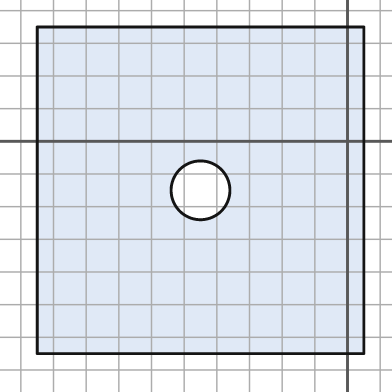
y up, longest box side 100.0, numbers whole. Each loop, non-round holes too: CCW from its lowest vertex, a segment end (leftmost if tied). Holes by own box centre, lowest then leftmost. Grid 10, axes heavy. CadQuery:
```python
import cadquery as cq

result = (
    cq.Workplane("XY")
    .moveTo(-95.0, -65.0)
    .lineTo(5.0, -65.0)
    .lineTo(5.0, 35.0)
    .lineTo(-95.0, 35.0)
    .close()
    .moveTo(-45.0, -15.0)
    .circle(9.0)
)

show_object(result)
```